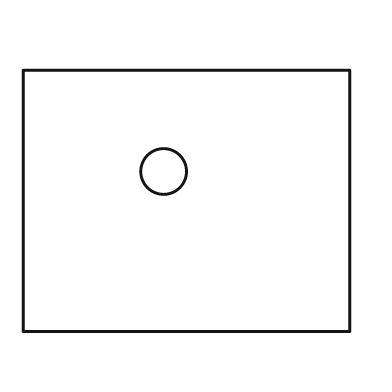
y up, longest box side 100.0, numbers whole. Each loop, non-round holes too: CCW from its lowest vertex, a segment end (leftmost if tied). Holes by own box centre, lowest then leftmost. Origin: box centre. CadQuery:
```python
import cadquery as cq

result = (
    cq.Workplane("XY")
    .moveTo(-50.0, -40.0)
    .lineTo(50.0, -40.0)
    .lineTo(50.0, 40.0)
    .lineTo(-50.0, 40.0)
    .close()
    .moveTo(-7.0, 9.0)
    .circle(7.0)
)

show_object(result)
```